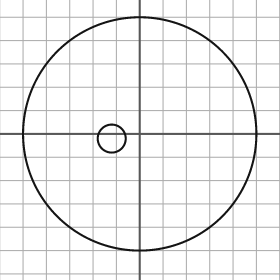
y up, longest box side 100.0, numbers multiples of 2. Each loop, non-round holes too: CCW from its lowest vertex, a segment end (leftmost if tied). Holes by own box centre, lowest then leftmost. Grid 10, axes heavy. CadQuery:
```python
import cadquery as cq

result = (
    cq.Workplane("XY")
    .moveTo(0.0, 0.0)
    .circle(50.0)
    .moveTo(-12.0, -2.0)
    .circle(6.0)
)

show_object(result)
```